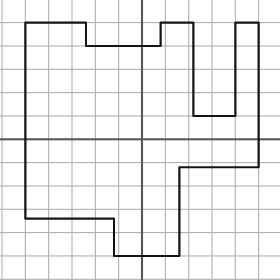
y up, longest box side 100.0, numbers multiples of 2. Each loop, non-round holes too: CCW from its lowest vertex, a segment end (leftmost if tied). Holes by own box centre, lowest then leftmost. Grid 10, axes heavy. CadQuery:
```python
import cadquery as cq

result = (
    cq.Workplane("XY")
    .moveTo(-12.0, -50.0)
    .lineTo(16.0, -50.0)
    .lineTo(16.0, -12.0)
    .lineTo(50.0, -12.0)
    .lineTo(50.0, 50.0)
    .lineTo(40.0, 50.0)
    .lineTo(40.0, 10.0)
    .lineTo(22.0, 10.0)
    .lineTo(22.0, 50.0)
    .lineTo(8.0, 50.0)
    .lineTo(8.0, 40.0)
    .lineTo(-24.0, 40.0)
    .lineTo(-24.0, 50.0)
    .lineTo(-50.0, 50.0)
    .lineTo(-50.0, -34.0)
    .lineTo(-12.0, -34.0)
    .close()
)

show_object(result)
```